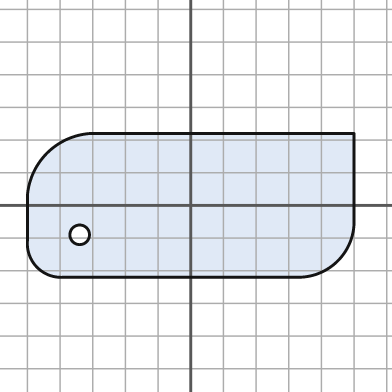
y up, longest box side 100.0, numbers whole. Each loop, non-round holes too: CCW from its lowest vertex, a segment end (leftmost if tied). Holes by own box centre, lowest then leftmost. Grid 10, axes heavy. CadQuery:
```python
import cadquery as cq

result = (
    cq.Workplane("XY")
    .moveTo(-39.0, -22.0)
    .lineTo(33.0, -22.0)
    .threePointArc((45.0, -17.0), (50.0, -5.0))
    .lineTo(50.0, 22.0)
    .lineTo(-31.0, 22.0)
    .threePointArc((-44.0, 16.0), (-50.0, 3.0))
    .lineTo(-50.0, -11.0)
    .threePointArc((-47.0, -19.0), (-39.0, -22.0))
    .close()
    .moveTo(-34.0, -9.0)
    .circle(3.0)
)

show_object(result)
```